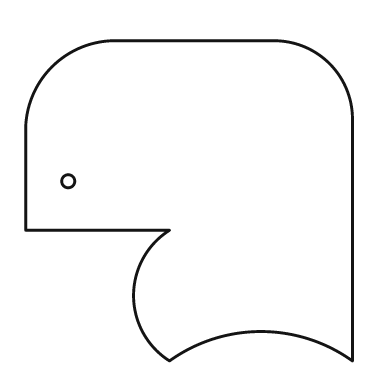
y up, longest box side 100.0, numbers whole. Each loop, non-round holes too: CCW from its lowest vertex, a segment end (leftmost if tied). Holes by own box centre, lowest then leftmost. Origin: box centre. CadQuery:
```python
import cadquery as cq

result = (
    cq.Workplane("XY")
    .moveTo(-6.0, -49.0)
    .threePointArc((22.0, -40.0), (50.0, -49.0))
    .lineTo(50.0, 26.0)
    .threePointArc((43.0, 42.0), (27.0, 49.0))
    .lineTo(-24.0, 49.0)
    .threePointArc((-42.0, 41.0), (-50.0, 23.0))
    .lineTo(-50.0, -9.0)
    .lineTo(-6.0, -9.0)
    .threePointArc((-17.0, -29.0), (-6.0, -49.0))
    .close()
    .moveTo(-37.0, 6.0)
    .circle(2.0)
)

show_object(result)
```